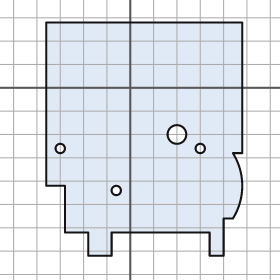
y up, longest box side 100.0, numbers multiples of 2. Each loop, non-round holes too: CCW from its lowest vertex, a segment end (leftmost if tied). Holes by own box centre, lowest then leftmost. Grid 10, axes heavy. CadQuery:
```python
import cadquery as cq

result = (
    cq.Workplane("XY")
    .moveTo(-18.0, -72.0)
    .lineTo(-8.0, -72.0)
    .lineTo(-8.0, -62.0)
    .lineTo(34.0, -62.0)
    .lineTo(34.0, -72.0)
    .lineTo(40.0, -72.0)
    .lineTo(40.0, -56.0)
    .lineTo(44.0, -56.0)
    .threePointArc((48.0, -42.0), (44.0, -28.0))
    .lineTo(48.0, -28.0)
    .lineTo(48.0, 28.0)
    .lineTo(-36.0, 28.0)
    .lineTo(-36.0, -42.0)
    .lineTo(-28.0, -42.0)
    .lineTo(-28.0, -62.0)
    .lineTo(-18.0, -62.0)
    .close()
    .moveTo(-6.0, -44.0)
    .circle(2.0)
    .moveTo(-30.0, -26.0)
    .circle(2.0)
    .moveTo(30.0, -26.0)
    .circle(2.0)
    .moveTo(20.0, -20.0)
    .circle(4.0)
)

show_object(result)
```